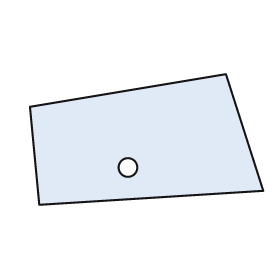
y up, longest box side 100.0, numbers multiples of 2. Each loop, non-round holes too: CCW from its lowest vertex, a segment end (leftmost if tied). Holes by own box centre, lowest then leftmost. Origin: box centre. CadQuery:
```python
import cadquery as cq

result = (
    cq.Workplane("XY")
    .moveTo(-46.0, -28.0)
    .lineTo(50.0, -22.0)
    .lineTo(34.0, 28.0)
    .lineTo(-50.0, 14.0)
    .close()
    .moveTo(-8.0, -12.0)
    .circle(4.0)
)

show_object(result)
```